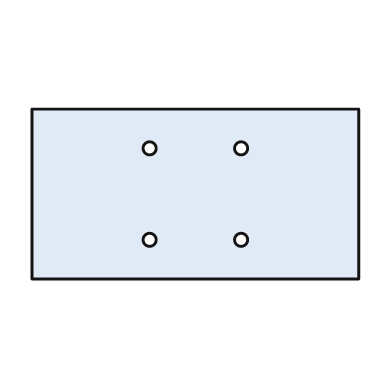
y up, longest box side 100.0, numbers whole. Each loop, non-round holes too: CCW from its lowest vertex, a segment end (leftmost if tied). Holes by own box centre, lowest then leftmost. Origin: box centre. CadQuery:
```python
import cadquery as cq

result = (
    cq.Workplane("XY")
    .moveTo(-50.0, -26.0)
    .lineTo(50.0, -26.0)
    .lineTo(50.0, 26.0)
    .lineTo(-50.0, 26.0)
    .close()
    .moveTo(-14.0, -14.0)
    .circle(2.0)
    .moveTo(14.0, -14.0)
    .circle(2.0)
    .moveTo(-14.0, 14.0)
    .circle(2.0)
    .moveTo(14.0, 14.0)
    .circle(2.0)
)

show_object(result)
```